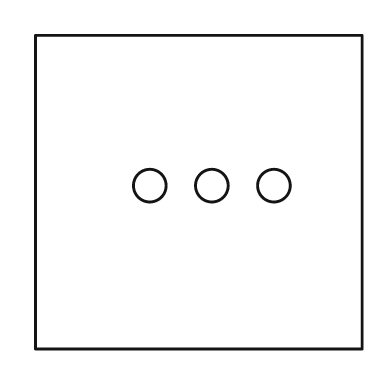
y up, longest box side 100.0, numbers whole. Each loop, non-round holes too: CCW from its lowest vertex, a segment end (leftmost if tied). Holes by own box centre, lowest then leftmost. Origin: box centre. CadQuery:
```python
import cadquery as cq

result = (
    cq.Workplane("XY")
    .moveTo(-50.0, -48.0)
    .lineTo(50.0, -48.0)
    .lineTo(50.0, 48.0)
    .lineTo(-50.0, 48.0)
    .close()
    .moveTo(-15.0, 2.0)
    .circle(5.0)
    .moveTo(4.0, 2.0)
    .circle(5.0)
    .moveTo(23.0, 2.0)
    .circle(5.0)
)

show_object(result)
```